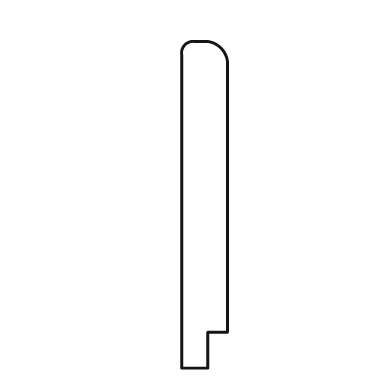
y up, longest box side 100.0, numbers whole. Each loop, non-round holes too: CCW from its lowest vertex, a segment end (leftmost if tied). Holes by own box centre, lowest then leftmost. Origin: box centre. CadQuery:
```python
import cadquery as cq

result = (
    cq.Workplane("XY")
    .moveTo(-7.0, -50.0)
    .lineTo(1.0, -50.0)
    .lineTo(1.0, -39.0)
    .lineTo(7.0, -39.0)
    .lineTo(7.0, 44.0)
    .threePointArc((5.0, 48.0), (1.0, 50.0))
    .lineTo(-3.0, 50.0)
    .threePointArc((-6.0, 49.0), (-7.0, 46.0))
    .close()
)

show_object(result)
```